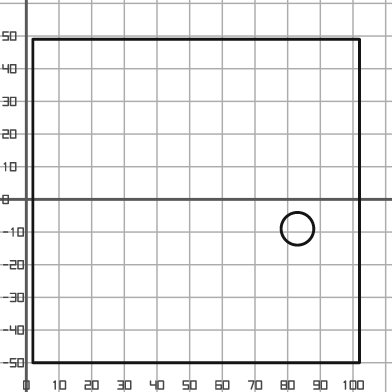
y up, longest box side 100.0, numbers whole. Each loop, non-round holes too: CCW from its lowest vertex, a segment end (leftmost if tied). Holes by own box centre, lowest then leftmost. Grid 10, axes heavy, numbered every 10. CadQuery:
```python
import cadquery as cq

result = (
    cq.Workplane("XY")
    .moveTo(2.0, -50.0)
    .lineTo(102.0, -50.0)
    .lineTo(102.0, 49.0)
    .lineTo(2.0, 49.0)
    .close()
    .moveTo(83.0, -9.0)
    .circle(5.0)
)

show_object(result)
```